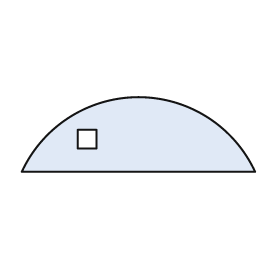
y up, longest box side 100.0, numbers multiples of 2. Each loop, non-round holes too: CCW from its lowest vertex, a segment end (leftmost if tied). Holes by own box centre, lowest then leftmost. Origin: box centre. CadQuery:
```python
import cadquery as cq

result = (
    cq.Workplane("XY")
    .moveTo(-50.0, -16.0)
    .lineTo(50.0, -16.0)
    .threePointArc((0.0, 16.0), (-50.0, -16.0))
    .close()
    .moveTo(-26.0, -6.0)
    .lineTo(-18.0, -6.0)
    .lineTo(-18.0, 2.0)
    .lineTo(-26.0, 2.0)
    .close()
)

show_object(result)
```